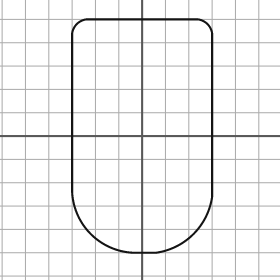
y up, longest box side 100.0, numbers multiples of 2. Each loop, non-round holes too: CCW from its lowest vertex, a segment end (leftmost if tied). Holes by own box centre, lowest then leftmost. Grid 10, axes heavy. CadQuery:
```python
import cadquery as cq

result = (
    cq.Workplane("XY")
    .moveTo(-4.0, -50.0)
    .lineTo(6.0, -50.0)
    .threePointArc((22.0, -42.0), (30.0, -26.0))
    .lineTo(30.0, 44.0)
    .threePointArc((28.0, 48.0), (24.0, 50.0))
    .lineTo(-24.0, 50.0)
    .threePointArc((-28.0, 48.0), (-30.0, 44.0))
    .lineTo(-30.0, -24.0)
    .threePointArc((-22.0, -42.0), (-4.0, -50.0))
    .close()
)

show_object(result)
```